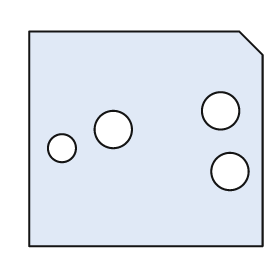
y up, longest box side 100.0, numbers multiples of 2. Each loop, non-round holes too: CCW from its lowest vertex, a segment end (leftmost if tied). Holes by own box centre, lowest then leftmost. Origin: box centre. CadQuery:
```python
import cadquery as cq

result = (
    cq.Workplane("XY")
    .moveTo(-50.0, -46.0)
    .lineTo(50.0, -46.0)
    .lineTo(50.0, 36.0)
    .lineTo(40.0, 46.0)
    .lineTo(-50.0, 46.0)
    .close()
    .moveTo(36.0, -14.0)
    .circle(8.0)
    .moveTo(-36.0, -4.0)
    .circle(6.0)
    .moveTo(-14.0, 4.0)
    .circle(8.0)
    .moveTo(32.0, 12.0)
    .circle(8.0)
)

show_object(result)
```